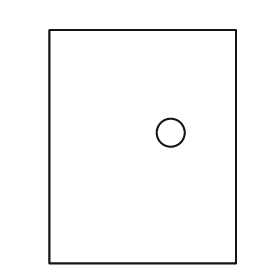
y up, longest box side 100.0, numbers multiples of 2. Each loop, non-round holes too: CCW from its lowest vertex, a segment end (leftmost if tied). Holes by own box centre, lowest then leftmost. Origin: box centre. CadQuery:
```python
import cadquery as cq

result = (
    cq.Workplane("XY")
    .moveTo(-40.0, -50.0)
    .lineTo(40.0, -50.0)
    .lineTo(40.0, 50.0)
    .lineTo(-40.0, 50.0)
    .close()
    .moveTo(12.0, 6.0)
    .circle(6.0)
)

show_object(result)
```